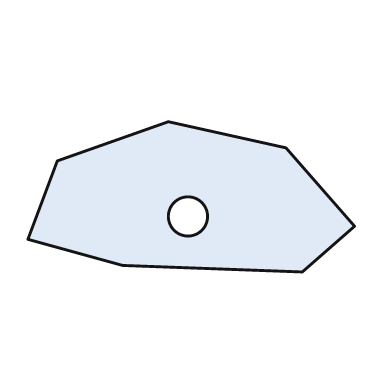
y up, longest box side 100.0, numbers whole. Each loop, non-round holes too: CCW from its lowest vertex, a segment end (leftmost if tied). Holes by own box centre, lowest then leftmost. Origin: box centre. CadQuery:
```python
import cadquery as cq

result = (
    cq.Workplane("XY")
    .moveTo(34.0, -23.0)
    .lineTo(50.0, -9.0)
    .lineTo(29.0, 15.0)
    .lineTo(-7.0, 23.0)
    .lineTo(-41.0, 11.0)
    .lineTo(-50.0, -13.0)
    .lineTo(-21.0, -21.0)
    .close()
    .moveTo(-1.0, -6.0)
    .circle(6.0)
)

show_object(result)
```